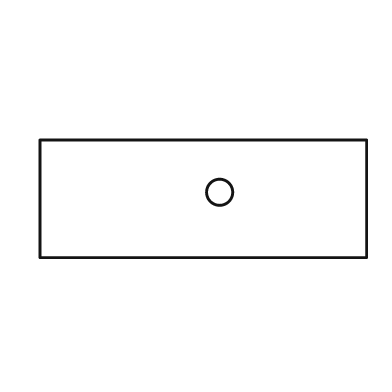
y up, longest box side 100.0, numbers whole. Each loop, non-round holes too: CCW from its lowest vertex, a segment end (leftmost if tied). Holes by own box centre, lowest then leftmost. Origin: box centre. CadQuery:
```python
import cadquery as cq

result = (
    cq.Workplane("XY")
    .moveTo(-50.0, -18.0)
    .lineTo(50.0, -18.0)
    .lineTo(50.0, 18.0)
    .lineTo(-50.0, 18.0)
    .close()
    .moveTo(5.0, 2.0)
    .circle(4.0)
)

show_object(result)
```